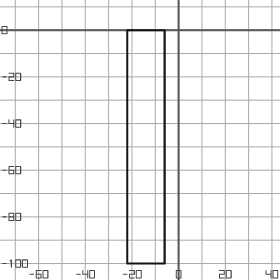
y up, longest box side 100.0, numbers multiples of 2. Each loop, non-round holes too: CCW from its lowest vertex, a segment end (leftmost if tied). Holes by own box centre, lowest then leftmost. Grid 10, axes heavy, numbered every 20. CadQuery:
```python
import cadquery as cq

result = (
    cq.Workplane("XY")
    .moveTo(-22.0, -100.0)
    .lineTo(-6.0, -100.0)
    .lineTo(-6.0, 0.0)
    .lineTo(-22.0, 0.0)
    .close()
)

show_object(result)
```